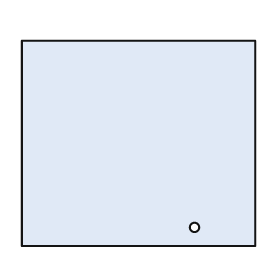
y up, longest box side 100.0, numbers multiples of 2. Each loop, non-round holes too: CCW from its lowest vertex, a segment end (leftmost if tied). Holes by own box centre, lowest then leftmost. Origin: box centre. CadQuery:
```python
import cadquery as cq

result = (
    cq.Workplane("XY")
    .moveTo(-50.0, -44.0)
    .lineTo(50.0, -44.0)
    .lineTo(50.0, 44.0)
    .lineTo(-50.0, 44.0)
    .close()
    .moveTo(24.0, -36.0)
    .circle(2.0)
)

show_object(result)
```